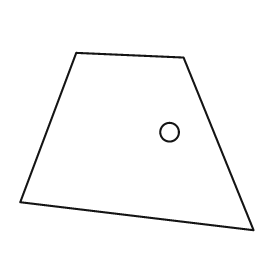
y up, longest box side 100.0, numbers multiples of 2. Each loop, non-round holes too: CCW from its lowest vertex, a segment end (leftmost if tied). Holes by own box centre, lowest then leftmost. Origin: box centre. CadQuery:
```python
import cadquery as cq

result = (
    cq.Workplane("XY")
    .moveTo(50.0, -38.0)
    .lineTo(20.0, 36.0)
    .lineTo(-26.0, 38.0)
    .lineTo(-50.0, -26.0)
    .close()
    .moveTo(14.0, 4.0)
    .circle(4.0)
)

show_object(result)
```